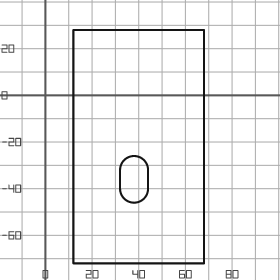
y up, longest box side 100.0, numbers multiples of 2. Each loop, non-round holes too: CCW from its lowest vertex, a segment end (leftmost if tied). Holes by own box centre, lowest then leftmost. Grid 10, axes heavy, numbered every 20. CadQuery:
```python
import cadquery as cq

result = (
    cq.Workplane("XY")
    .moveTo(12.0, -72.0)
    .lineTo(68.0, -72.0)
    .lineTo(68.0, 28.0)
    .lineTo(12.0, 28.0)
    .close()
    .moveTo(32.0, -40.0)
    .threePointArc((38.0, -46.0), (44.0, -40.0))
    .lineTo(44.0, -32.0)
    .threePointArc((38.0, -26.0), (32.0, -32.0))
    .close()
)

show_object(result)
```